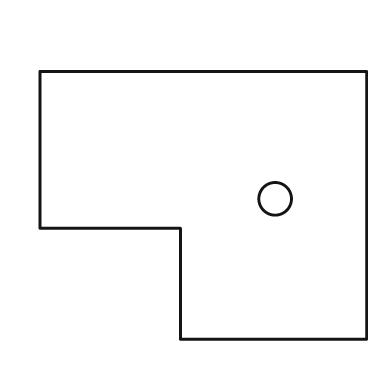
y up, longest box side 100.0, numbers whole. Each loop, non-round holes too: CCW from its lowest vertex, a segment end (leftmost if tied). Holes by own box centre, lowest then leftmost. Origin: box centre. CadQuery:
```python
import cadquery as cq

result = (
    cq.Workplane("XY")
    .moveTo(-7.0, -41.0)
    .lineTo(50.0, -41.0)
    .lineTo(50.0, 41.0)
    .lineTo(-50.0, 41.0)
    .lineTo(-50.0, -7.0)
    .lineTo(-7.0, -7.0)
    .close()
    .moveTo(22.0, 2.0)
    .circle(5.0)
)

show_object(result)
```